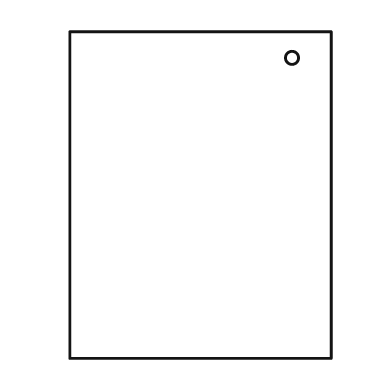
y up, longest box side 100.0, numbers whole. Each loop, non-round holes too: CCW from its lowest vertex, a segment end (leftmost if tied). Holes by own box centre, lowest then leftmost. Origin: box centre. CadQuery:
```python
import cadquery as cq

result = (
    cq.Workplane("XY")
    .moveTo(-40.0, -50.0)
    .lineTo(40.0, -50.0)
    .lineTo(40.0, 50.0)
    .lineTo(-40.0, 50.0)
    .close()
    .moveTo(28.0, 42.0)
    .circle(2.0)
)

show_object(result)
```